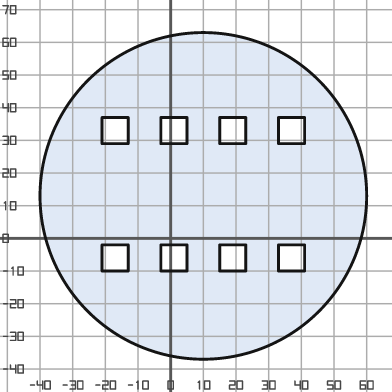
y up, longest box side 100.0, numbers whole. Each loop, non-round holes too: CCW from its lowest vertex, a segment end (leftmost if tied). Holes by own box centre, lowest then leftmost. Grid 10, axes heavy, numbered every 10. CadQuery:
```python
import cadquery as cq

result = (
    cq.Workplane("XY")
    .moveTo(10.0, 13.0)
    .circle(50.0)
    .moveTo(-21.0, -10.0)
    .lineTo(-13.0, -10.0)
    .lineTo(-13.0, -2.0)
    .lineTo(-21.0, -2.0)
    .close()
    .moveTo(-3.0, -10.0)
    .lineTo(5.0, -10.0)
    .lineTo(5.0, -2.0)
    .lineTo(-3.0, -2.0)
    .close()
    .moveTo(15.0, -10.0)
    .lineTo(23.0, -10.0)
    .lineTo(23.0, -2.0)
    .lineTo(15.0, -2.0)
    .close()
    .moveTo(33.0, -10.0)
    .lineTo(41.0, -10.0)
    .lineTo(41.0, -2.0)
    .lineTo(33.0, -2.0)
    .close()
    .moveTo(-21.0, 29.0)
    .lineTo(-13.0, 29.0)
    .lineTo(-13.0, 37.0)
    .lineTo(-21.0, 37.0)
    .close()
    .moveTo(-3.0, 29.0)
    .lineTo(5.0, 29.0)
    .lineTo(5.0, 37.0)
    .lineTo(-3.0, 37.0)
    .close()
    .moveTo(15.0, 29.0)
    .lineTo(23.0, 29.0)
    .lineTo(23.0, 37.0)
    .lineTo(15.0, 37.0)
    .close()
    .moveTo(33.0, 29.0)
    .lineTo(41.0, 29.0)
    .lineTo(41.0, 37.0)
    .lineTo(33.0, 37.0)
    .close()
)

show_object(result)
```